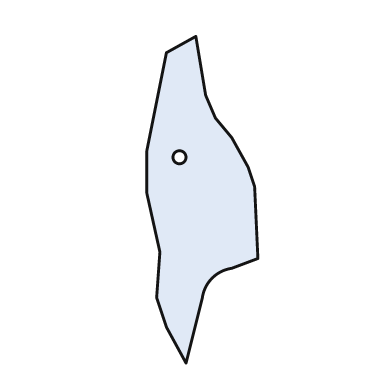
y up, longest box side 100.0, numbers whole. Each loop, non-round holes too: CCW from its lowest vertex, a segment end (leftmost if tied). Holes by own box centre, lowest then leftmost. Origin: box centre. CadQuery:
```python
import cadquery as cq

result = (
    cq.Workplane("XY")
    .moveTo(-5.0, -50.0)
    .lineTo(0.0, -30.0)
    .threePointArc((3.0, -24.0), (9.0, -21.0))
    .lineTo(17.0, -18.0)
    .lineTo(16.0, 4.0)
    .lineTo(14.0, 10.0)
    .lineTo(9.0, 19.0)
    .lineTo(4.0, 25.0)
    .lineTo(1.0, 32.0)
    .lineTo(-2.0, 50.0)
    .lineTo(-11.0, 45.0)
    .lineTo(-17.0, 15.0)
    .lineTo(-17.0, 2.0)
    .lineTo(-13.0, -16.0)
    .lineTo(-14.0, -30.0)
    .lineTo(-11.0, -39.0)
    .close()
    .moveTo(-7.0, 13.0)
    .circle(2.0)
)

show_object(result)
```